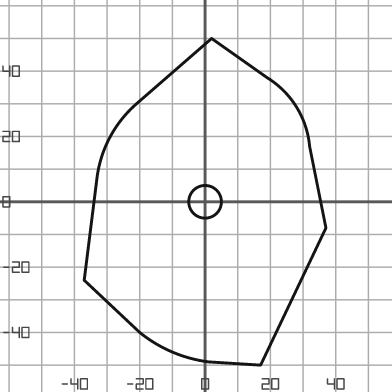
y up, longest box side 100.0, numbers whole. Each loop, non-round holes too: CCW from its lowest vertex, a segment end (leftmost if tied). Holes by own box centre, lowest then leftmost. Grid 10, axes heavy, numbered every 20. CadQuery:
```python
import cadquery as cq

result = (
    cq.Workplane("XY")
    .moveTo(17.0, -50.0)
    .lineTo(37.0, -8.0)
    .lineTo(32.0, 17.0)
    .threePointArc((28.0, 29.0), (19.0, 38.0))
    .lineTo(2.0, 50.0)
    .lineTo(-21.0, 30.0)
    .threePointArc((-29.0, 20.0), (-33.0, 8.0))
    .lineTo(-37.0, -24.0)
    .lineTo(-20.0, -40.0)
    .threePointArc((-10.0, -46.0), (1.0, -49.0))
    .close()
    .moveTo(0.0, 0.0)
    .circle(5.0)
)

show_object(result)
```